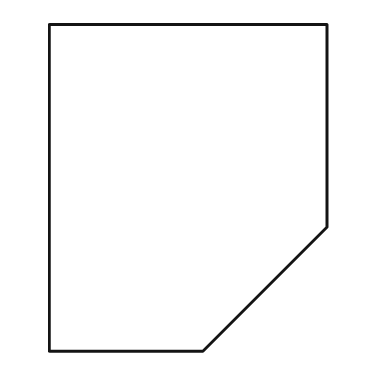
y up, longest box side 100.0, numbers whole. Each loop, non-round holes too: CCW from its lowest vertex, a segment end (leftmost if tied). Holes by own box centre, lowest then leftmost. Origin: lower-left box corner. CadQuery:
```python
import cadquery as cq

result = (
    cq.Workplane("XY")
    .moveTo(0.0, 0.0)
    .lineTo(47.0, 0.0)
    .lineTo(85.0, 38.0)
    .lineTo(85.0, 100.0)
    .lineTo(0.0, 100.0)
    .close()
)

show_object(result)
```